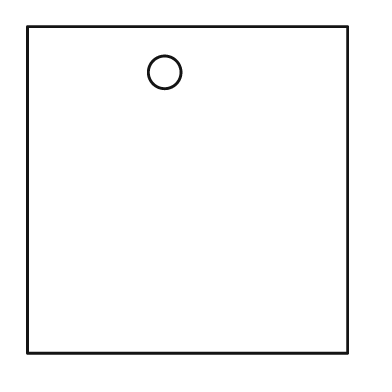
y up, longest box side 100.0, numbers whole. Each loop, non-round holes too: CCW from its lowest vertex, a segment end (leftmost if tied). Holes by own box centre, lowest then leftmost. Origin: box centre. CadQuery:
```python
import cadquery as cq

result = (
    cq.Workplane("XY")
    .moveTo(-49.0, -50.0)
    .lineTo(49.0, -50.0)
    .lineTo(49.0, 50.0)
    .lineTo(-49.0, 50.0)
    .close()
    .moveTo(-7.0, 36.0)
    .circle(5.0)
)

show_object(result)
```